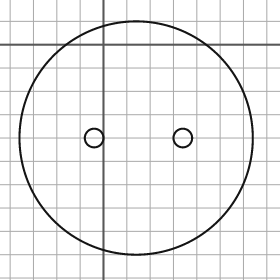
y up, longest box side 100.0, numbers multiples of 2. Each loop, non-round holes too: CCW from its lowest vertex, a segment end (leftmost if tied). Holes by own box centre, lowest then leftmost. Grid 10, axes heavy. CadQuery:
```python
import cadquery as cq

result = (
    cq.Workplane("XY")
    .moveTo(14.0, -40.0)
    .circle(50.0)
    .moveTo(-4.0, -40.0)
    .circle(4.0)
    .moveTo(34.0, -40.0)
    .circle(4.0)
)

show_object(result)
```